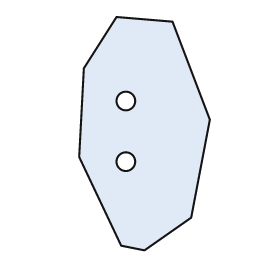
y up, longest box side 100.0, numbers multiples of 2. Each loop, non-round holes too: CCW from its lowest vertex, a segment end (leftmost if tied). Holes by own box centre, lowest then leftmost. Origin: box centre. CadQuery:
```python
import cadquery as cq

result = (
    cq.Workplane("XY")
    .moveTo(0.0, -50.0)
    .lineTo(20.0, -36.0)
    .lineTo(28.0, 6.0)
    .lineTo(12.0, 48.0)
    .lineTo(-12.0, 50.0)
    .lineTo(-26.0, 28.0)
    .lineTo(-28.0, -10.0)
    .lineTo(-10.0, -48.0)
    .close()
    .moveTo(-8.0, -12.0)
    .circle(4.0)
    .moveTo(-8.0, 14.0)
    .circle(4.0)
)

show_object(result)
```